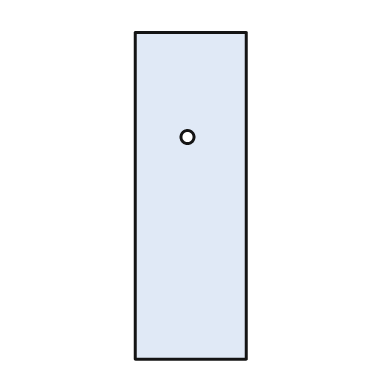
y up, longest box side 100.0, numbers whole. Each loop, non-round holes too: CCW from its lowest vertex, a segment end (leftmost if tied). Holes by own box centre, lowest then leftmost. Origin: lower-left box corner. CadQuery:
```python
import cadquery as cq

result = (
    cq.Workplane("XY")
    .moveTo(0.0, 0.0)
    .lineTo(34.0, 0.0)
    .lineTo(34.0, 100.0)
    .lineTo(0.0, 100.0)
    .close()
    .moveTo(16.0, 68.0)
    .circle(2.0)
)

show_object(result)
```